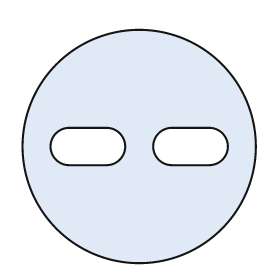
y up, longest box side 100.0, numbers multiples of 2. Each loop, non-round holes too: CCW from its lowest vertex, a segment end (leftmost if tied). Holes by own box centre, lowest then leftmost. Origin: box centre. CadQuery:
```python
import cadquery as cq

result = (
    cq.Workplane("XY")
    .moveTo(0.0, 0.0)
    .circle(50.0)
    .moveTo(-30.0, -8.0)
    .lineTo(-14.0, -8.0)
    .threePointArc((-6.0, 0.0), (-14.0, 8.0))
    .lineTo(-30.0, 8.0)
    .threePointArc((-38.0, 0.0), (-30.0, -8.0))
    .close()
    .moveTo(14.0, -8.0)
    .lineTo(30.0, -8.0)
    .threePointArc((38.0, 0.0), (30.0, 8.0))
    .lineTo(14.0, 8.0)
    .threePointArc((6.0, 0.0), (14.0, -8.0))
    .close()
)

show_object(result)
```